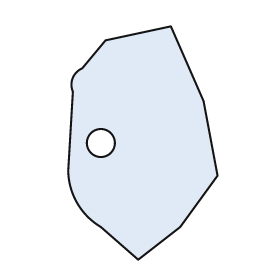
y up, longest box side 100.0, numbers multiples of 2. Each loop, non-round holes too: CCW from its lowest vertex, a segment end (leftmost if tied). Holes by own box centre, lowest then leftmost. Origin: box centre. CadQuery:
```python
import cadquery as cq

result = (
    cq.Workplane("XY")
    .moveTo(-2.0, -50.0)
    .lineTo(16.0, -36.0)
    .lineTo(32.0, -14.0)
    .lineTo(26.0, 18.0)
    .lineTo(12.0, 50.0)
    .lineTo(-16.0, 44.0)
    .lineTo(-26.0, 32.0)
    .threePointArc((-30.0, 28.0), (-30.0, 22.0))
    .lineTo(-32.0, -12.0)
    .threePointArc((-28.0, -26.0), (-18.0, -36.0))
    .close()
    .moveTo(-18.0, 0.0)
    .circle(6.0)
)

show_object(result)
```